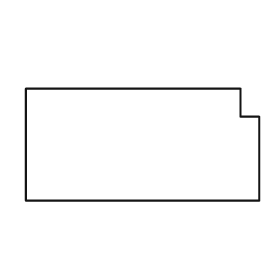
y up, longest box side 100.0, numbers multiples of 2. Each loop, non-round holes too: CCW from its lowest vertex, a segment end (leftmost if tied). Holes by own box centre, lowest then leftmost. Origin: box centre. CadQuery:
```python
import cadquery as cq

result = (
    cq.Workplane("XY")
    .moveTo(-50.0, -24.0)
    .lineTo(50.0, -24.0)
    .lineTo(50.0, 12.0)
    .lineTo(42.0, 12.0)
    .lineTo(42.0, 24.0)
    .lineTo(-50.0, 24.0)
    .close()
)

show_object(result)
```